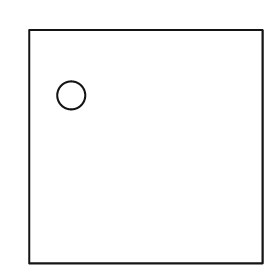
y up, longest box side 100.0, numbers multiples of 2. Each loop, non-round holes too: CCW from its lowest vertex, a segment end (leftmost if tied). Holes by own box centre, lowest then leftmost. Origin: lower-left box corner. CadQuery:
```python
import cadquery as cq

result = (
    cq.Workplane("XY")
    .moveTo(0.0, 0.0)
    .lineTo(100.0, 0.0)
    .lineTo(100.0, 100.0)
    .lineTo(0.0, 100.0)
    .close()
    .moveTo(18.0, 72.0)
    .circle(6.0)
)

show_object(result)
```